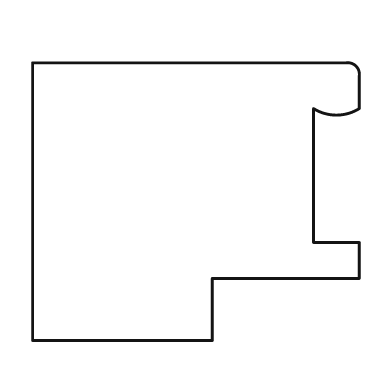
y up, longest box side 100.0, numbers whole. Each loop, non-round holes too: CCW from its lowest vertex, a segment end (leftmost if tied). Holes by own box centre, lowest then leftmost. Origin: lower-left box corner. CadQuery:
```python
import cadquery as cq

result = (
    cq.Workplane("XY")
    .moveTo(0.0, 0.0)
    .lineTo(55.0, 0.0)
    .lineTo(55.0, 19.0)
    .lineTo(100.0, 19.0)
    .lineTo(100.0, 30.0)
    .lineTo(86.0, 30.0)
    .lineTo(86.0, 71.0)
    .threePointArc((93.0, 69.0), (100.0, 71.0))
    .lineTo(100.0, 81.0)
    .threePointArc((99.0, 84.0), (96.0, 85.0))
    .lineTo(0.0, 85.0)
    .close()
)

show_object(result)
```